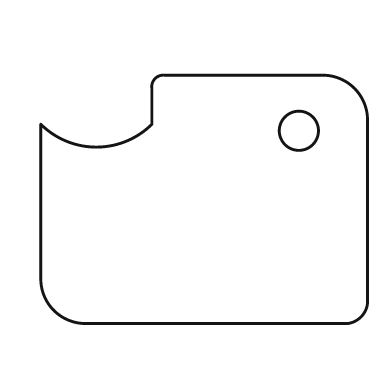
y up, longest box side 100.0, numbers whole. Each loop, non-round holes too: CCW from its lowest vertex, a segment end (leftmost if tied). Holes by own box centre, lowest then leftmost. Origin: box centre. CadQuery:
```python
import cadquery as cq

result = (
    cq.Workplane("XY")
    .moveTo(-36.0, -38.0)
    .lineTo(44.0, -38.0)
    .threePointArc((48.0, -36.0), (50.0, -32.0))
    .lineTo(50.0, 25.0)
    .threePointArc((46.0, 34.0), (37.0, 38.0))
    .lineTo(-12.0, 38.0)
    .threePointArc((-15.0, 37.0), (-16.0, 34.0))
    .lineTo(-16.0, 23.0)
    .threePointArc((-33.0, 16.0), (-50.0, 23.0))
    .lineTo(-50.0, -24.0)
    .threePointArc((-46.0, -34.0), (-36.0, -38.0))
    .close()
    .moveTo(29.0, 21.0)
    .circle(6.0)
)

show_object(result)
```